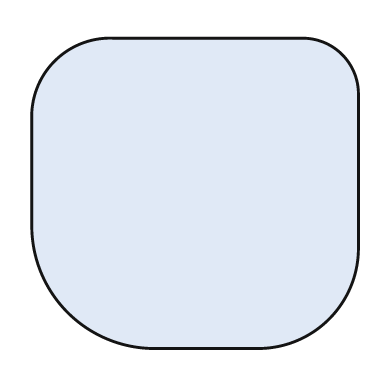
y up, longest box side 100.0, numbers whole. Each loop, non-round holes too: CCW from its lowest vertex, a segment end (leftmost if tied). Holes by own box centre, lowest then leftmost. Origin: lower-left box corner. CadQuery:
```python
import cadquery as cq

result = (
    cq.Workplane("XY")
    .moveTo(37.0, 0.0)
    .lineTo(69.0, 0.0)
    .threePointArc((91.0, 9.0), (100.0, 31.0))
    .lineTo(100.0, 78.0)
    .threePointArc((95.0, 90.0), (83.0, 95.0))
    .lineTo(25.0, 95.0)
    .threePointArc((7.0, 88.0), (0.0, 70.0))
    .lineTo(0.0, 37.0)
    .threePointArc((11.0, 11.0), (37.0, 0.0))
    .close()
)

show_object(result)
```